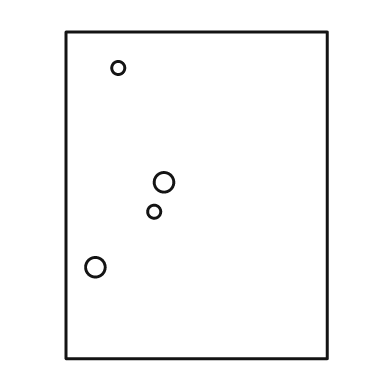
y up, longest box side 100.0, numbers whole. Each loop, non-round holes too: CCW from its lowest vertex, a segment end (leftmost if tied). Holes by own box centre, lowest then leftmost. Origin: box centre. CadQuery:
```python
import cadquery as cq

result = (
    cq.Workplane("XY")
    .moveTo(-40.0, -50.0)
    .lineTo(40.0, -50.0)
    .lineTo(40.0, 50.0)
    .lineTo(-40.0, 50.0)
    .close()
    .moveTo(-31.0, -22.0)
    .circle(3.0)
    .moveTo(-13.0, -5.0)
    .circle(2.0)
    .moveTo(-10.0, 4.0)
    .circle(3.0)
    .moveTo(-24.0, 39.0)
    .circle(2.0)
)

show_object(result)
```